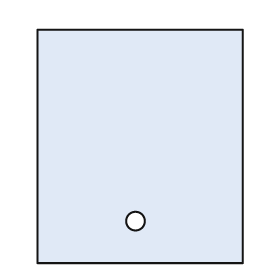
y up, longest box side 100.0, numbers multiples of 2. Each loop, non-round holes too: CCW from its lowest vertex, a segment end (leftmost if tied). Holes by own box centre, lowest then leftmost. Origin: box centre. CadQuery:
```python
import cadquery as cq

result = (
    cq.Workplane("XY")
    .moveTo(-44.0, -50.0)
    .lineTo(44.0, -50.0)
    .lineTo(44.0, 50.0)
    .lineTo(-44.0, 50.0)
    .close()
    .moveTo(-2.0, -32.0)
    .circle(4.0)
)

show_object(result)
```